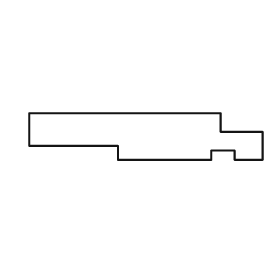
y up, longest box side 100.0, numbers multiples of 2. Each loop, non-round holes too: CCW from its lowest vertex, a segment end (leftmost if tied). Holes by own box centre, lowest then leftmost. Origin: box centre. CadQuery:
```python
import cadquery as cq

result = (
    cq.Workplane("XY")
    .moveTo(-12.0, -10.0)
    .lineTo(28.0, -10.0)
    .lineTo(28.0, -6.0)
    .lineTo(38.0, -6.0)
    .lineTo(38.0, -10.0)
    .lineTo(50.0, -10.0)
    .lineTo(50.0, 2.0)
    .lineTo(32.0, 2.0)
    .lineTo(32.0, 10.0)
    .lineTo(-50.0, 10.0)
    .lineTo(-50.0, -4.0)
    .lineTo(-12.0, -4.0)
    .close()
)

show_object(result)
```